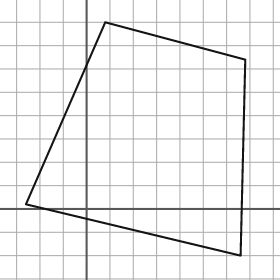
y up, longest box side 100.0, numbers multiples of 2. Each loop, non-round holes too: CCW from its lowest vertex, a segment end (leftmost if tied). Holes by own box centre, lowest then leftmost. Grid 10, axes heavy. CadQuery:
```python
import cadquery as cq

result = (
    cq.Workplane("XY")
    .moveTo(66.0, -20.0)
    .lineTo(68.0, 64.0)
    .lineTo(8.0, 80.0)
    .lineTo(-26.0, 2.0)
    .close()
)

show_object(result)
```